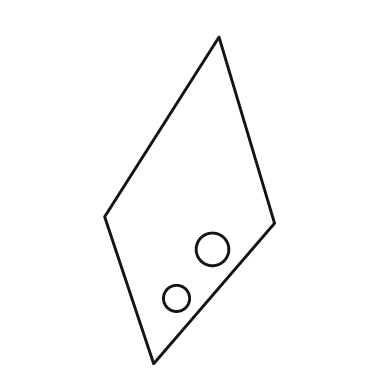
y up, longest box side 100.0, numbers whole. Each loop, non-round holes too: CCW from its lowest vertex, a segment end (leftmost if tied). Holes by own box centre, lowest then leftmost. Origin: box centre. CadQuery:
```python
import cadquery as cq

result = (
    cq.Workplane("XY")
    .moveTo(-11.0, -50.0)
    .lineTo(26.0, -7.0)
    .lineTo(9.0, 50.0)
    .lineTo(-26.0, -5.0)
    .close()
    .moveTo(-4.0, -30.0)
    .circle(4.0)
    .moveTo(7.0, -15.0)
    .circle(5.0)
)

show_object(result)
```